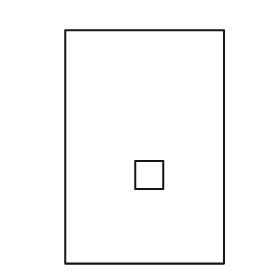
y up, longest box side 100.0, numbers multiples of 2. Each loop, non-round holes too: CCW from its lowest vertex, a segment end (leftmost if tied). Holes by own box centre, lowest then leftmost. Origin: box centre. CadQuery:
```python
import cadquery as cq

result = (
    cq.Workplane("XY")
    .moveTo(-34.0, -50.0)
    .lineTo(34.0, -50.0)
    .lineTo(34.0, 50.0)
    .lineTo(-34.0, 50.0)
    .close()
    .moveTo(-4.0, -18.0)
    .lineTo(8.0, -18.0)
    .lineTo(8.0, -6.0)
    .lineTo(-4.0, -6.0)
    .close()
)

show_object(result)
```